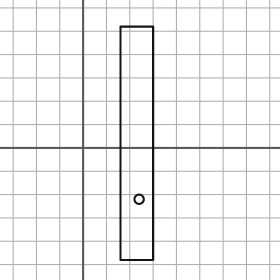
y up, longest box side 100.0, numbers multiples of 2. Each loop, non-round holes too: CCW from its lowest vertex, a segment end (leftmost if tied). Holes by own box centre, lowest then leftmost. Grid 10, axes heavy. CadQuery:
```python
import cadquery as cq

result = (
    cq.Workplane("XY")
    .moveTo(16.0, -48.0)
    .lineTo(30.0, -48.0)
    .lineTo(30.0, 52.0)
    .lineTo(16.0, 52.0)
    .close()
    .moveTo(24.0, -22.0)
    .circle(2.0)
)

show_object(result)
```